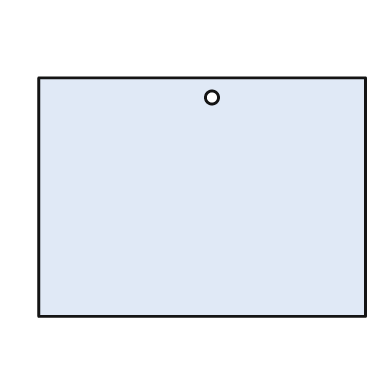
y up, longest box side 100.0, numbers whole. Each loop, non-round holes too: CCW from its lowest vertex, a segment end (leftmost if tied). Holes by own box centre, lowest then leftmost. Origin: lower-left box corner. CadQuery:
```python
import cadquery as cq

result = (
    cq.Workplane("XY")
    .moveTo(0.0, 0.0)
    .lineTo(100.0, 0.0)
    .lineTo(100.0, 73.0)
    .lineTo(0.0, 73.0)
    .close()
    .moveTo(53.0, 67.0)
    .circle(2.0)
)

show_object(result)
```